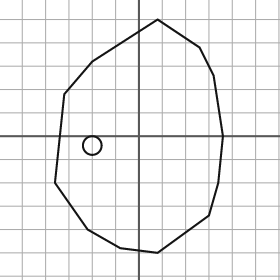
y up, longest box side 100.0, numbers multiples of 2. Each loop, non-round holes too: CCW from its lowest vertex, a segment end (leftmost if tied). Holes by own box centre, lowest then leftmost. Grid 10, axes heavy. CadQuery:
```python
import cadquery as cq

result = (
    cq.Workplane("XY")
    .moveTo(8.0, -50.0)
    .lineTo(30.0, -34.0)
    .lineTo(34.0, -20.0)
    .lineTo(36.0, 0.0)
    .lineTo(32.0, 26.0)
    .lineTo(26.0, 38.0)
    .lineTo(8.0, 50.0)
    .lineTo(-20.0, 32.0)
    .lineTo(-32.0, 18.0)
    .lineTo(-36.0, -20.0)
    .lineTo(-22.0, -40.0)
    .lineTo(-8.0, -48.0)
    .close()
    .moveTo(-20.0, -4.0)
    .circle(4.0)
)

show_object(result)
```